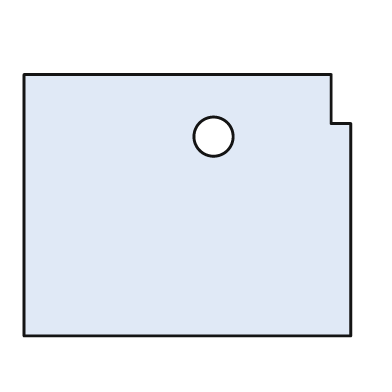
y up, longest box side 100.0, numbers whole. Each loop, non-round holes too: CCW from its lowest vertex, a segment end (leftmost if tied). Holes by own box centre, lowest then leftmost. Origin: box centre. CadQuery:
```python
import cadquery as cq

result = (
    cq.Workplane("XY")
    .moveTo(-50.0, -40.0)
    .lineTo(50.0, -40.0)
    .lineTo(50.0, 25.0)
    .lineTo(44.0, 25.0)
    .lineTo(44.0, 40.0)
    .lineTo(-50.0, 40.0)
    .close()
    .moveTo(8.0, 21.0)
    .circle(6.0)
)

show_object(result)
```